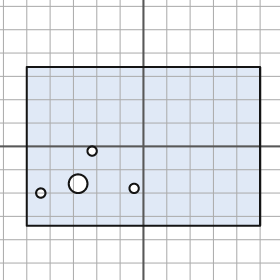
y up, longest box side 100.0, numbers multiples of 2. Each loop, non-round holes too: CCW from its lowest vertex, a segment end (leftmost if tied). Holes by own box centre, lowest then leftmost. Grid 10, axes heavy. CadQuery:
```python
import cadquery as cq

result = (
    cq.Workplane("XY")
    .moveTo(-50.0, -34.0)
    .lineTo(50.0, -34.0)
    .lineTo(50.0, 34.0)
    .lineTo(-50.0, 34.0)
    .close()
    .moveTo(-44.0, -20.0)
    .circle(2.0)
    .moveTo(-4.0, -18.0)
    .circle(2.0)
    .moveTo(-28.0, -16.0)
    .circle(4.0)
    .moveTo(-22.0, -2.0)
    .circle(2.0)
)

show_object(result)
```